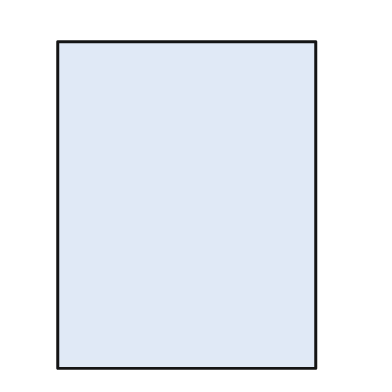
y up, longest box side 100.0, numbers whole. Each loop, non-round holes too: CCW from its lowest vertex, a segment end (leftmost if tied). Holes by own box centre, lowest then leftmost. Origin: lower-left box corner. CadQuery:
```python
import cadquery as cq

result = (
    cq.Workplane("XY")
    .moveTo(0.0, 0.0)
    .lineTo(79.0, 0.0)
    .lineTo(79.0, 100.0)
    .lineTo(0.0, 100.0)
    .close()
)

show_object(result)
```